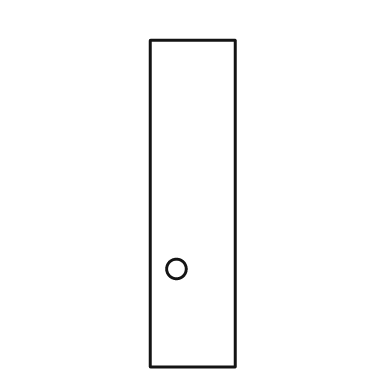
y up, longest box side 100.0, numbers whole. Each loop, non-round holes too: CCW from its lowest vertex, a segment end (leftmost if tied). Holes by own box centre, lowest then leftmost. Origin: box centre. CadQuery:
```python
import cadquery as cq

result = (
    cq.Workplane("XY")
    .moveTo(-13.0, -50.0)
    .lineTo(13.0, -50.0)
    .lineTo(13.0, 50.0)
    .lineTo(-13.0, 50.0)
    .close()
    .moveTo(-5.0, -20.0)
    .circle(3.0)
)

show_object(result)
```